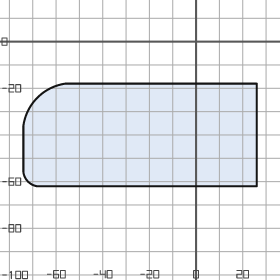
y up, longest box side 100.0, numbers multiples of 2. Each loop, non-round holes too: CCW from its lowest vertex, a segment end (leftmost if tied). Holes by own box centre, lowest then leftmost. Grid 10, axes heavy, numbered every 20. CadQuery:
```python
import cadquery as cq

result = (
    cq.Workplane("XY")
    .moveTo(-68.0, -62.0)
    .lineTo(26.0, -62.0)
    .lineTo(26.0, -18.0)
    .lineTo(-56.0, -18.0)
    .threePointArc((-68.0, -24.0), (-74.0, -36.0))
    .lineTo(-74.0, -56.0)
    .threePointArc((-72.0, -60.0), (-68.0, -62.0))
    .close()
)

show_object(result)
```